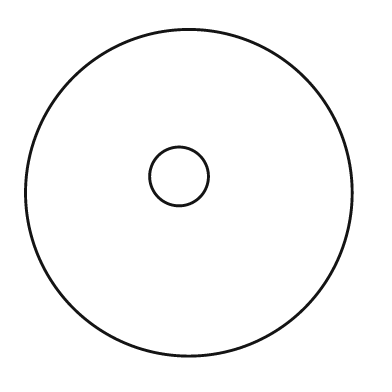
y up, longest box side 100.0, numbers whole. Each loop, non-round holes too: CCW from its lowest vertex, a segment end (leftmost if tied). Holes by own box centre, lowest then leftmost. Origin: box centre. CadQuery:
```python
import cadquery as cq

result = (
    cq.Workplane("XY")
    .moveTo(0.0, 0.0)
    .circle(50.0)
    .moveTo(-3.0, 5.0)
    .circle(9.0)
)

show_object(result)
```